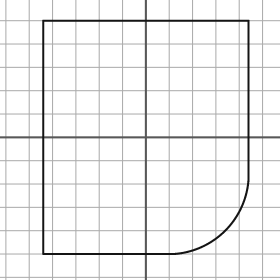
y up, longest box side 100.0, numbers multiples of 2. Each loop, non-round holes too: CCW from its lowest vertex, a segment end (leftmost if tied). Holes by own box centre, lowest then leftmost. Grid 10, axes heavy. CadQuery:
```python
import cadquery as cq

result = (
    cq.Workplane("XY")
    .moveTo(-44.0, -50.0)
    .lineTo(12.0, -50.0)
    .threePointArc((34.0, -40.0), (44.0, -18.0))
    .lineTo(44.0, 50.0)
    .lineTo(-44.0, 50.0)
    .close()
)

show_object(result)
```